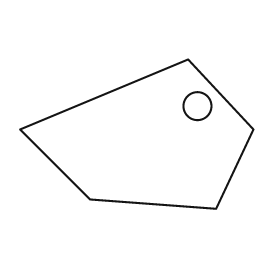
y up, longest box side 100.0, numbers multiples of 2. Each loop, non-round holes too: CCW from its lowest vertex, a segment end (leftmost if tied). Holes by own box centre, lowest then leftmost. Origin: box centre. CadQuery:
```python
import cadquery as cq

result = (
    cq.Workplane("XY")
    .moveTo(34.0, -32.0)
    .lineTo(50.0, 2.0)
    .lineTo(22.0, 32.0)
    .lineTo(-50.0, 2.0)
    .lineTo(-20.0, -28.0)
    .close()
    .moveTo(26.0, 12.0)
    .circle(6.0)
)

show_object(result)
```